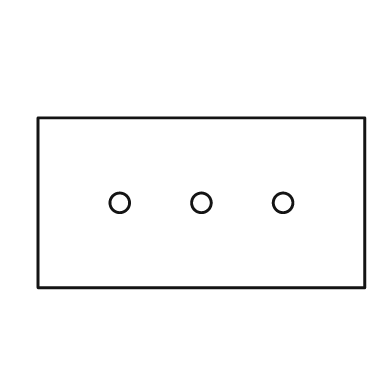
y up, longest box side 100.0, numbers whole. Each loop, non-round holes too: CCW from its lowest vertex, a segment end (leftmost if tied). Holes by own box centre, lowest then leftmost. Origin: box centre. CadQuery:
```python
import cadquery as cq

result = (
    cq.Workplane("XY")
    .moveTo(-50.0, -26.0)
    .lineTo(50.0, -26.0)
    .lineTo(50.0, 26.0)
    .lineTo(-50.0, 26.0)
    .close()
    .moveTo(-25.0, 0.0)
    .circle(3.0)
    .moveTo(0.0, 0.0)
    .circle(3.0)
    .moveTo(25.0, 0.0)
    .circle(3.0)
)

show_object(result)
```